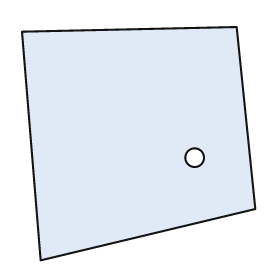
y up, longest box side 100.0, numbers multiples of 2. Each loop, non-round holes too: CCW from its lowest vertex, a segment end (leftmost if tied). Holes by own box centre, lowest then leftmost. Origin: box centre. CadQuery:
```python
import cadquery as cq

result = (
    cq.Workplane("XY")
    .moveTo(-42.0, -50.0)
    .lineTo(50.0, -28.0)
    .lineTo(42.0, 50.0)
    .lineTo(-50.0, 48.0)
    .close()
    .moveTo(24.0, -6.0)
    .circle(4.0)
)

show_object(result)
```